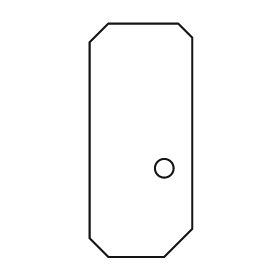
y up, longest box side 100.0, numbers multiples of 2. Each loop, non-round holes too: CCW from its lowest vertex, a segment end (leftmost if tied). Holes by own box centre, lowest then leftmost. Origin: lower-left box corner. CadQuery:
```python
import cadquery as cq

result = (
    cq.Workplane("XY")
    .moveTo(8.0, 0.0)
    .lineTo(32.0, 0.0)
    .lineTo(44.0, 12.0)
    .lineTo(44.0, 94.0)
    .lineTo(38.0, 100.0)
    .lineTo(8.0, 100.0)
    .lineTo(0.0, 92.0)
    .lineTo(0.0, 8.0)
    .close()
    .moveTo(32.0, 38.0)
    .circle(4.0)
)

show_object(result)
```